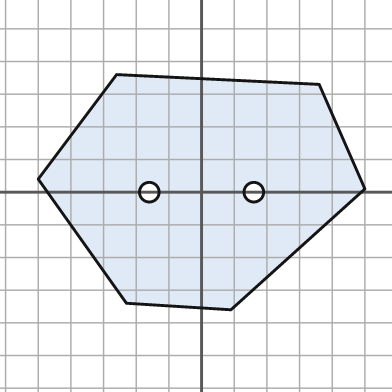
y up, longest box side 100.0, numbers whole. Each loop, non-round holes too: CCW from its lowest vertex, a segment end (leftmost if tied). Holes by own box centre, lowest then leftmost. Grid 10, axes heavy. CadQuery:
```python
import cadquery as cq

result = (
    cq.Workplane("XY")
    .moveTo(9.0, -36.0)
    .lineTo(50.0, 1.0)
    .lineTo(36.0, 33.0)
    .lineTo(-26.0, 36.0)
    .lineTo(-50.0, 4.0)
    .lineTo(-23.0, -34.0)
    .close()
    .moveTo(-16.0, 0.0)
    .circle(3.0)
    .moveTo(16.0, 0.0)
    .circle(3.0)
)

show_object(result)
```